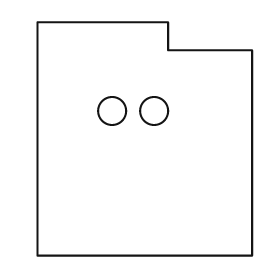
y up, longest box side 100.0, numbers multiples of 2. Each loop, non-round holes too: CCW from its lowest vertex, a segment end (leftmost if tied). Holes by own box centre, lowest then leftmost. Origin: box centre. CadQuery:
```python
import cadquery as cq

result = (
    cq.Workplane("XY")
    .moveTo(-46.0, -50.0)
    .lineTo(46.0, -50.0)
    .lineTo(46.0, 38.0)
    .lineTo(10.0, 38.0)
    .lineTo(10.0, 50.0)
    .lineTo(-46.0, 50.0)
    .close()
    .moveTo(-14.0, 12.0)
    .circle(6.0)
    .moveTo(4.0, 12.0)
    .circle(6.0)
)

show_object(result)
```